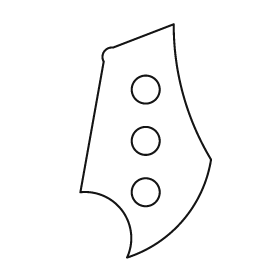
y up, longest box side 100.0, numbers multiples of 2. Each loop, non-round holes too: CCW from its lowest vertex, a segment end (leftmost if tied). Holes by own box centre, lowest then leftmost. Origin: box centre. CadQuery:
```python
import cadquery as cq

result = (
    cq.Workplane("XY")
    .moveTo(-8.0, -50.0)
    .threePointArc((16.0, -34.0), (28.0, -8.0))
    .threePointArc((16.0, 20.0), (12.0, 50.0))
    .lineTo(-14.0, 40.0)
    .threePointArc((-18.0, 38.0), (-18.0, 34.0))
    .lineTo(-28.0, -22.0)
    .threePointArc((-10.0, -30.0), (-8.0, -50.0))
    .close()
    .moveTo(0.0, -22.0)
    .circle(6.0)
    .moveTo(0.0, 0.0)
    .circle(6.0)
    .moveTo(0.0, 22.0)
    .circle(6.0)
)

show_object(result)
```